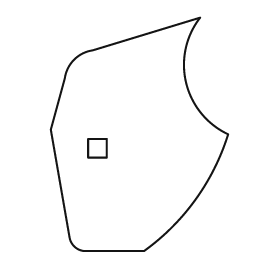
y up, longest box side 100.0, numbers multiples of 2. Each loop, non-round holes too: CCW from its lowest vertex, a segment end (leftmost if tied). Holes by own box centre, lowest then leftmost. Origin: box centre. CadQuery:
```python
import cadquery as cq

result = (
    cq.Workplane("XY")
    .moveTo(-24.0, -50.0)
    .lineTo(2.0, -50.0)
    .threePointArc((24.0, -28.0), (38.0, 0.0))
    .threePointArc((20.0, 22.0), (26.0, 50.0))
    .lineTo(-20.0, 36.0)
    .threePointArc((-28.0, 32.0), (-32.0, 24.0))
    .lineTo(-38.0, 2.0)
    .lineTo(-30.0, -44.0)
    .threePointArc((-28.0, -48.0), (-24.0, -50.0))
    .close()
    .moveTo(-22.0, -10.0)
    .lineTo(-14.0, -10.0)
    .lineTo(-14.0, -2.0)
    .lineTo(-22.0, -2.0)
    .close()
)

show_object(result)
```